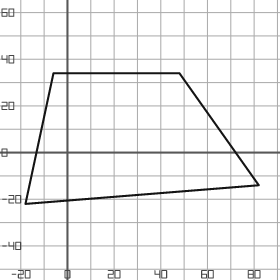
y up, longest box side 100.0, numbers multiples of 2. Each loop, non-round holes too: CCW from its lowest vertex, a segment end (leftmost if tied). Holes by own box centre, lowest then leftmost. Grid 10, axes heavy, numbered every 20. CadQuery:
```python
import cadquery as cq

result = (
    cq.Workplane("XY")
    .moveTo(-18.0, -22.0)
    .lineTo(82.0, -14.0)
    .lineTo(48.0, 34.0)
    .lineTo(-6.0, 34.0)
    .close()
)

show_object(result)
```